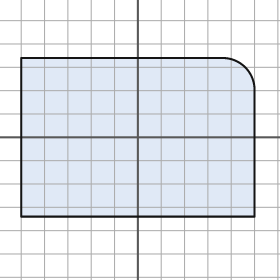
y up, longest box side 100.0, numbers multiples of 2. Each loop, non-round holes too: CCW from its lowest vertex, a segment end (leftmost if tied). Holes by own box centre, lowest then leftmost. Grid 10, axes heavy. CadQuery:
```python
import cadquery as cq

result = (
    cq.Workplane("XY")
    .moveTo(-50.0, -34.0)
    .lineTo(50.0, -34.0)
    .lineTo(50.0, 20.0)
    .threePointArc((46.0, 30.0), (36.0, 34.0))
    .lineTo(-50.0, 34.0)
    .close()
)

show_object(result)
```